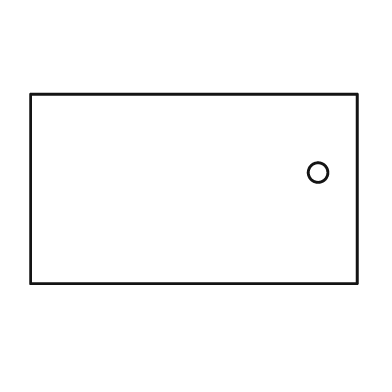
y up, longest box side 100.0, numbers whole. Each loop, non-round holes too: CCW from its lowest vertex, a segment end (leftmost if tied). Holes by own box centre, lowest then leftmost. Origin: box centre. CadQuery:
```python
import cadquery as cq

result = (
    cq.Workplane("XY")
    .moveTo(-50.0, -29.0)
    .lineTo(50.0, -29.0)
    .lineTo(50.0, 29.0)
    .lineTo(-50.0, 29.0)
    .close()
    .moveTo(38.0, 5.0)
    .circle(3.0)
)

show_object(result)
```